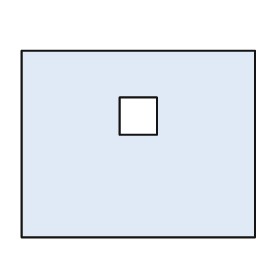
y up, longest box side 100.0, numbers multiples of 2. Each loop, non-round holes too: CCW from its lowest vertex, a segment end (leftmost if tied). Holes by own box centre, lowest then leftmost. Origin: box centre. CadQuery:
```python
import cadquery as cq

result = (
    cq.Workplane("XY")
    .moveTo(-50.0, -40.0)
    .lineTo(50.0, -40.0)
    .lineTo(50.0, 40.0)
    .lineTo(-50.0, 40.0)
    .close()
    .moveTo(-8.0, 4.0)
    .lineTo(8.0, 4.0)
    .lineTo(8.0, 20.0)
    .lineTo(-8.0, 20.0)
    .close()
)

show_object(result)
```